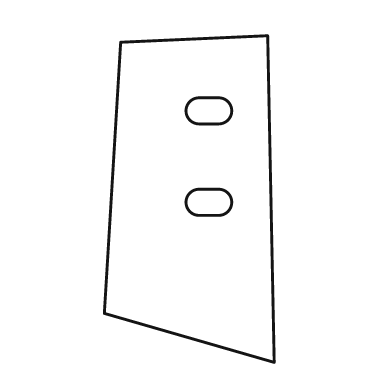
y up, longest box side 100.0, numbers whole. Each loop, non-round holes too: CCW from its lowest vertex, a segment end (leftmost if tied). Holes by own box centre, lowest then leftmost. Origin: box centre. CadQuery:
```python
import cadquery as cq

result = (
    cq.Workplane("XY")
    .moveTo(26.0, -50.0)
    .lineTo(24.0, 50.0)
    .lineTo(-21.0, 48.0)
    .lineTo(-26.0, -35.0)
    .close()
    .moveTo(3.0, -5.0)
    .lineTo(9.0, -5.0)
    .threePointArc((13.0, -1.0), (9.0, 3.0))
    .lineTo(3.0, 3.0)
    .threePointArc((-1.0, -1.0), (3.0, -5.0))
    .close()
    .moveTo(3.0, 23.0)
    .lineTo(9.0, 23.0)
    .threePointArc((13.0, 27.0), (9.0, 31.0))
    .lineTo(3.0, 31.0)
    .threePointArc((-1.0, 27.0), (3.0, 23.0))
    .close()
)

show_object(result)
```